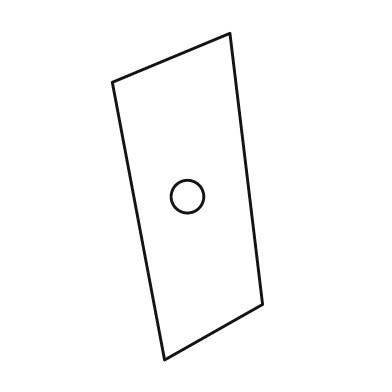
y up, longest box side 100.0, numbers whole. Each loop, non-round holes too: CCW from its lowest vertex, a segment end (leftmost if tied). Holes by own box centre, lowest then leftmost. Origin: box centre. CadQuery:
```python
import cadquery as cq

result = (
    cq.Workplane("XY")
    .moveTo(-7.0, -50.0)
    .lineTo(23.0, -33.0)
    .lineTo(13.0, 50.0)
    .lineTo(-23.0, 35.0)
    .close()
    .moveTo(0.0, 0.0)
    .circle(5.0)
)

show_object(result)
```